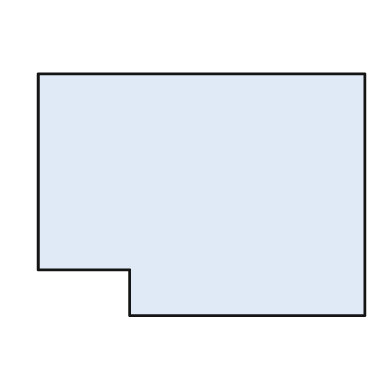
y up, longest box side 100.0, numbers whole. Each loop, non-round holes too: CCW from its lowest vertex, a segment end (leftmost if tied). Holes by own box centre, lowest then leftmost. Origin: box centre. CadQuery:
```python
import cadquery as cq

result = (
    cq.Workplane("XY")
    .moveTo(-22.0, -37.0)
    .lineTo(50.0, -37.0)
    .lineTo(50.0, 37.0)
    .lineTo(-50.0, 37.0)
    .lineTo(-50.0, -23.0)
    .lineTo(-22.0, -23.0)
    .close()
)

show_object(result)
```